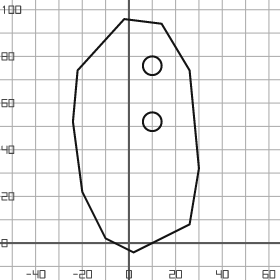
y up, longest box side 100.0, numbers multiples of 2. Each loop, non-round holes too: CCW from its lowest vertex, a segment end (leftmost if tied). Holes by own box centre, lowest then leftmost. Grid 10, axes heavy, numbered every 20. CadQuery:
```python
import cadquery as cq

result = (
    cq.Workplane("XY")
    .moveTo(2.0, -4.0)
    .lineTo(26.0, 8.0)
    .lineTo(30.0, 32.0)
    .lineTo(26.0, 74.0)
    .lineTo(14.0, 94.0)
    .lineTo(-2.0, 96.0)
    .lineTo(-22.0, 74.0)
    .lineTo(-24.0, 52.0)
    .lineTo(-20.0, 22.0)
    .lineTo(-10.0, 2.0)
    .close()
    .moveTo(10.0, 52.0)
    .circle(4.0)
    .moveTo(10.0, 76.0)
    .circle(4.0)
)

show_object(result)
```